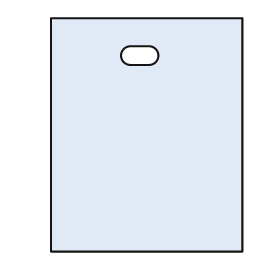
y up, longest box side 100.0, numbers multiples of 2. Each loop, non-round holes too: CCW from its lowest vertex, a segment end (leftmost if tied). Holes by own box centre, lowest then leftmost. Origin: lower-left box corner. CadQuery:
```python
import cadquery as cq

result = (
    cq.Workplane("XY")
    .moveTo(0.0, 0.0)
    .lineTo(82.0, 0.0)
    .lineTo(82.0, 100.0)
    .lineTo(0.0, 100.0)
    .close()
    .moveTo(34.0, 80.0)
    .lineTo(42.0, 80.0)
    .threePointArc((46.0, 84.0), (42.0, 88.0))
    .lineTo(34.0, 88.0)
    .threePointArc((30.0, 84.0), (34.0, 80.0))
    .close()
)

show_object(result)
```